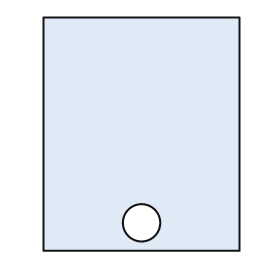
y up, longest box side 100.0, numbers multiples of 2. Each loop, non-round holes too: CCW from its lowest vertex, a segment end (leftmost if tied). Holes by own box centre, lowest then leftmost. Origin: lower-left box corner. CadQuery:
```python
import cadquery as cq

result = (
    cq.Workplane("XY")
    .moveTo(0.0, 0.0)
    .lineTo(84.0, 0.0)
    .lineTo(84.0, 100.0)
    .lineTo(0.0, 100.0)
    .close()
    .moveTo(42.0, 12.0)
    .circle(8.0)
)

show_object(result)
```